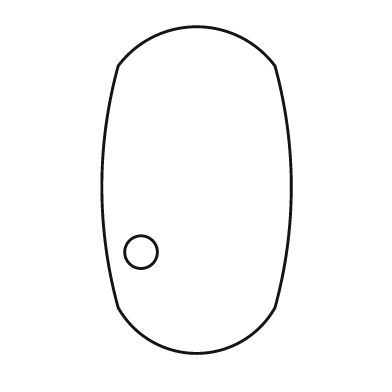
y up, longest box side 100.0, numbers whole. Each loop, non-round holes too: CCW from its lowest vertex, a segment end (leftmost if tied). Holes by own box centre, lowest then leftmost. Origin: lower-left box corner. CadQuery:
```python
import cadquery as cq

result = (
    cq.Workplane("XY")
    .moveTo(5.0, 14.0)
    .threePointArc((29.0, 0.0), (53.0, 14.0))
    .threePointArc((58.0, 51.0), (53.0, 88.0))
    .threePointArc((29.0, 100.0), (5.0, 88.0))
    .threePointArc((0.0, 51.0), (5.0, 14.0))
    .close()
    .moveTo(12.0, 31.0)
    .circle(5.0)
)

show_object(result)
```